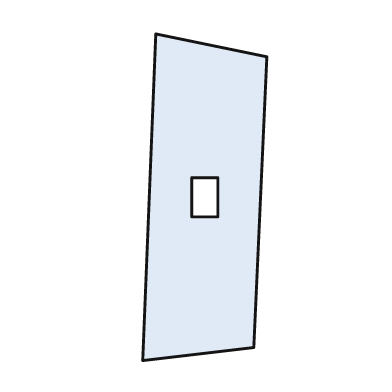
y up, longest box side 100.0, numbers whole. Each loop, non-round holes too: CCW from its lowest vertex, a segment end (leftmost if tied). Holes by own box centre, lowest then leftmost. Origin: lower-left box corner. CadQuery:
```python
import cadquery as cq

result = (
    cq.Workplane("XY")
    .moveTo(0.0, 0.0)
    .lineTo(34.0, 4.0)
    .lineTo(38.0, 93.0)
    .lineTo(4.0, 100.0)
    .close()
    .moveTo(15.0, 44.0)
    .lineTo(23.0, 44.0)
    .lineTo(23.0, 56.0)
    .lineTo(15.0, 56.0)
    .close()
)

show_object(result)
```